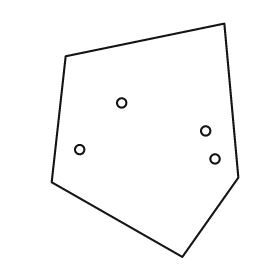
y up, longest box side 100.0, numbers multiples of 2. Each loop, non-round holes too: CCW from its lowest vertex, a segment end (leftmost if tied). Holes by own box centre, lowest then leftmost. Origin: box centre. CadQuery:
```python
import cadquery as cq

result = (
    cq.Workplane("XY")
    .moveTo(16.0, -50.0)
    .lineTo(40.0, -16.0)
    .lineTo(34.0, 50.0)
    .lineTo(-34.0, 36.0)
    .lineTo(-40.0, -18.0)
    .close()
    .moveTo(30.0, -8.0)
    .circle(2.0)
    .moveTo(-28.0, -4.0)
    .circle(2.0)
    .moveTo(26.0, 4.0)
    .circle(2.0)
    .moveTo(-10.0, 16.0)
    .circle(2.0)
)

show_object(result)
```